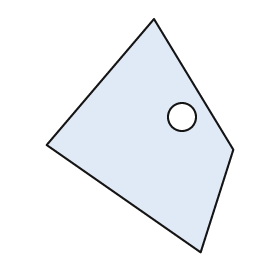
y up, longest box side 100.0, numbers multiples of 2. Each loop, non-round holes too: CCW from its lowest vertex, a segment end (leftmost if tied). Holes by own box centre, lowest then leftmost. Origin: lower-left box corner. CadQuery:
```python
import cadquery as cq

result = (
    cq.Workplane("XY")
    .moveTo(66.0, 0.0)
    .lineTo(80.0, 44.0)
    .lineTo(46.0, 100.0)
    .lineTo(0.0, 46.0)
    .close()
    .moveTo(58.0, 58.0)
    .circle(6.0)
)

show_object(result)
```